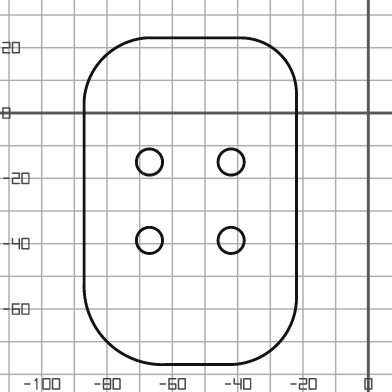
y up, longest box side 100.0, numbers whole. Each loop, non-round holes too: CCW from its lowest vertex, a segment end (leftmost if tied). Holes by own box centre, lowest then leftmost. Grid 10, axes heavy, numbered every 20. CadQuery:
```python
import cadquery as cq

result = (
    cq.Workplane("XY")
    .moveTo(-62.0, -77.0)
    .lineTo(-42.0, -77.0)
    .threePointArc((-28.0, -71.0), (-22.0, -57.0))
    .lineTo(-22.0, 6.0)
    .threePointArc((-27.0, 18.0), (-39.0, 23.0))
    .lineTo(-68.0, 23.0)
    .threePointArc((-81.0, 17.0), (-87.0, 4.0))
    .lineTo(-87.0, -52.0)
    .threePointArc((-80.0, -70.0), (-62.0, -77.0))
    .close()
    .moveTo(-67.0, -39.0)
    .circle(4.0)
    .moveTo(-42.0, -39.0)
    .circle(4.0)
    .moveTo(-67.0, -15.0)
    .circle(4.0)
    .moveTo(-42.0, -15.0)
    .circle(4.0)
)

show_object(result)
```